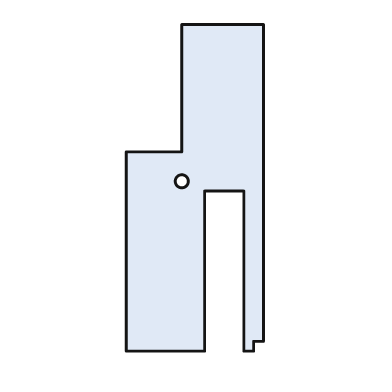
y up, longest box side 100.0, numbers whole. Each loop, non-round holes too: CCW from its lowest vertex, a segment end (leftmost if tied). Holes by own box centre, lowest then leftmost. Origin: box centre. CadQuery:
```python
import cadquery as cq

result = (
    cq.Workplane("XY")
    .moveTo(-21.0, -50.0)
    .lineTo(3.0, -50.0)
    .lineTo(3.0, -1.0)
    .lineTo(15.0, -1.0)
    .lineTo(15.0, -50.0)
    .lineTo(18.0, -50.0)
    .lineTo(18.0, -47.0)
    .lineTo(21.0, -47.0)
    .lineTo(21.0, 50.0)
    .lineTo(-4.0, 50.0)
    .lineTo(-4.0, 11.0)
    .lineTo(-21.0, 11.0)
    .close()
    .moveTo(-4.0, 2.0)
    .circle(2.0)
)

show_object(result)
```